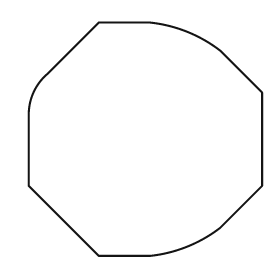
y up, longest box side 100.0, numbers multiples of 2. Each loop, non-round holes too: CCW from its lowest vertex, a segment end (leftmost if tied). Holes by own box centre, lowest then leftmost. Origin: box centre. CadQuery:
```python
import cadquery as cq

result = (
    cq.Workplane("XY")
    .moveTo(-20.0, -50.0)
    .lineTo(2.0, -50.0)
    .threePointArc((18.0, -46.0), (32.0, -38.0))
    .lineTo(50.0, -20.0)
    .lineTo(50.0, 20.0)
    .lineTo(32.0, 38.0)
    .threePointArc((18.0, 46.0), (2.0, 50.0))
    .lineTo(-20.0, 50.0)
    .lineTo(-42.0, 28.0)
    .threePointArc((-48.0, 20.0), (-50.0, 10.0))
    .lineTo(-50.0, -20.0)
    .close()
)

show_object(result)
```